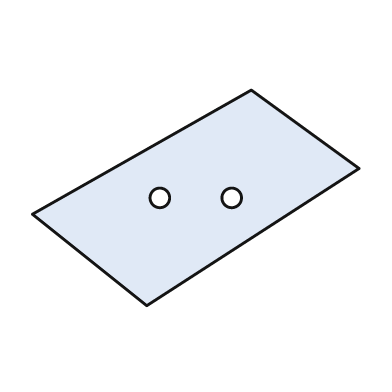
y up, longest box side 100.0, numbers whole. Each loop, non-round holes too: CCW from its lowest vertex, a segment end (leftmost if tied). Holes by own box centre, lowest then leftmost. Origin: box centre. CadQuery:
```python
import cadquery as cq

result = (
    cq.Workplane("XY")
    .moveTo(-15.0, -33.0)
    .lineTo(50.0, 9.0)
    .lineTo(17.0, 33.0)
    .lineTo(-50.0, -5.0)
    .close()
    .moveTo(-11.0, 0.0)
    .circle(3.0)
    .moveTo(11.0, 0.0)
    .circle(3.0)
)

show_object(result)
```